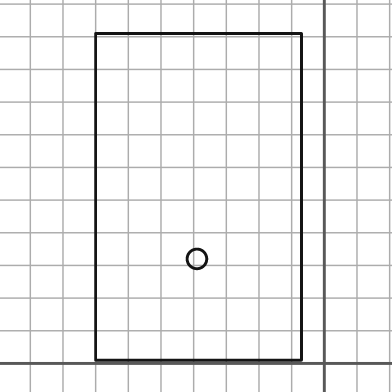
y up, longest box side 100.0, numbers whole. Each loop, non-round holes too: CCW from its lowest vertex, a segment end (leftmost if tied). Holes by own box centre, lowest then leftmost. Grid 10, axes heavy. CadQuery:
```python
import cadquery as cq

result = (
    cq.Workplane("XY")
    .moveTo(-70.0, 1.0)
    .lineTo(-7.0, 1.0)
    .lineTo(-7.0, 101.0)
    .lineTo(-70.0, 101.0)
    .close()
    .moveTo(-39.0, 32.0)
    .circle(3.0)
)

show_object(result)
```